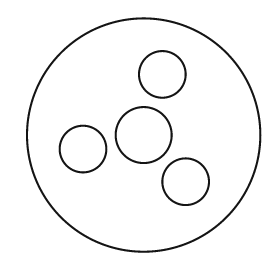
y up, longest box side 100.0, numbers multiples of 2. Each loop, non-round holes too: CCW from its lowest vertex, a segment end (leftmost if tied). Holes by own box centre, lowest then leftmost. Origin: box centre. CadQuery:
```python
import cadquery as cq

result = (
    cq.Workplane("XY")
    .moveTo(0.0, 0.0)
    .circle(50.0)
    .moveTo(18.0, -20.0)
    .circle(10.0)
    .moveTo(-26.0, -6.0)
    .circle(10.0)
    .moveTo(0.0, 0.0)
    .circle(12.0)
    .moveTo(8.0, 26.0)
    .circle(10.0)
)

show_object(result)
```